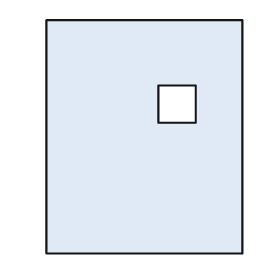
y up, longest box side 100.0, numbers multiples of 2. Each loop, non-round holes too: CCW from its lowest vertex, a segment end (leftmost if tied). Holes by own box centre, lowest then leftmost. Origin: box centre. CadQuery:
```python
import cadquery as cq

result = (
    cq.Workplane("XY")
    .moveTo(-42.0, -50.0)
    .lineTo(42.0, -50.0)
    .lineTo(42.0, 50.0)
    .lineTo(-42.0, 50.0)
    .close()
    .moveTo(6.0, 6.0)
    .lineTo(22.0, 6.0)
    .lineTo(22.0, 22.0)
    .lineTo(6.0, 22.0)
    .close()
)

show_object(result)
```